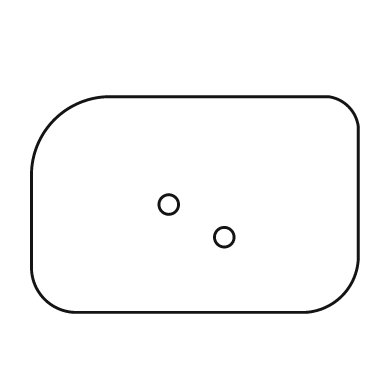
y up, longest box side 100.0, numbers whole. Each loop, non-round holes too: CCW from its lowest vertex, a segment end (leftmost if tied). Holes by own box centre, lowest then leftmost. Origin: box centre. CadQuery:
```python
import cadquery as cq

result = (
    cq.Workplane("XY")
    .moveTo(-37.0, -33.0)
    .lineTo(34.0, -33.0)
    .threePointArc((45.0, -28.0), (50.0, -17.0))
    .lineTo(50.0, 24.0)
    .threePointArc((47.0, 30.0), (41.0, 33.0))
    .lineTo(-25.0, 33.0)
    .threePointArc((-43.0, 26.0), (-50.0, 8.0))
    .lineTo(-50.0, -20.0)
    .threePointArc((-46.0, -29.0), (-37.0, -33.0))
    .close()
    .moveTo(9.0, -10.0)
    .circle(3.0)
    .moveTo(-8.0, 0.0)
    .circle(3.0)
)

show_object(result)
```